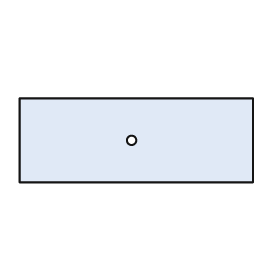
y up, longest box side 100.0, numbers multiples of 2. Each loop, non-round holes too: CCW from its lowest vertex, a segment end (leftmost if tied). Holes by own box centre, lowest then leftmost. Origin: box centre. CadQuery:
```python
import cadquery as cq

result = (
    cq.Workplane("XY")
    .moveTo(-50.0, -18.0)
    .lineTo(50.0, -18.0)
    .lineTo(50.0, 18.0)
    .lineTo(-50.0, 18.0)
    .close()
    .moveTo(-2.0, 0.0)
    .circle(2.0)
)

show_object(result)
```